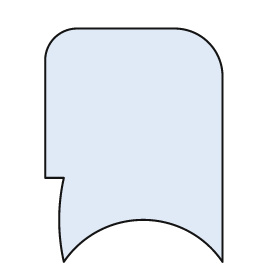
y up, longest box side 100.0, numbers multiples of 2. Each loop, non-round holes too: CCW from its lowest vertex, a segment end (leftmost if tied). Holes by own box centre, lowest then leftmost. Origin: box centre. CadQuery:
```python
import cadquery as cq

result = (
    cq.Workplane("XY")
    .moveTo(-30.0, -50.0)
    .threePointArc((4.0, -32.0), (38.0, -50.0))
    .lineTo(38.0, 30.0)
    .threePointArc((32.0, 44.0), (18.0, 50.0))
    .lineTo(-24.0, 50.0)
    .threePointArc((-34.0, 46.0), (-38.0, 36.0))
    .lineTo(-38.0, -14.0)
    .lineTo(-30.0, -14.0)
    .threePointArc((-32.0, -32.0), (-30.0, -50.0))
    .close()
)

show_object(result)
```